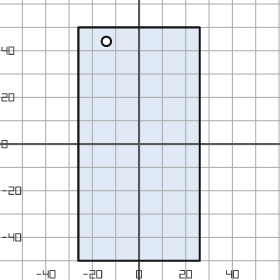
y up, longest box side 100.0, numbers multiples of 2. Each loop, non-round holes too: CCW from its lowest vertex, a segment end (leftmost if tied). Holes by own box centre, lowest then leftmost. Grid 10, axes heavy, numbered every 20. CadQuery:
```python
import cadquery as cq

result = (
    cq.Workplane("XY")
    .moveTo(-26.0, -50.0)
    .lineTo(26.0, -50.0)
    .lineTo(26.0, 50.0)
    .lineTo(-26.0, 50.0)
    .close()
    .moveTo(-14.0, 44.0)
    .circle(2.0)
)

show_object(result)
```